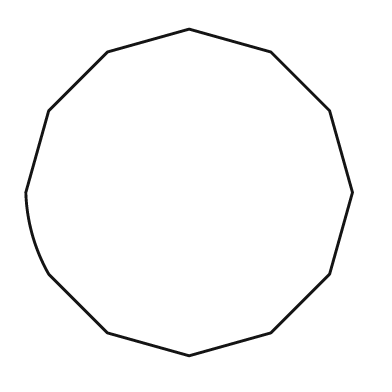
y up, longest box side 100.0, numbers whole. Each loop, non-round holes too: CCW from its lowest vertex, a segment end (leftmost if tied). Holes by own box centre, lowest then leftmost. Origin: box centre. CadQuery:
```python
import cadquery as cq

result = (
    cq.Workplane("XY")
    .moveTo(0.0, -50.0)
    .lineTo(25.0, -43.0)
    .lineTo(43.0, -25.0)
    .lineTo(50.0, 0.0)
    .lineTo(43.0, 25.0)
    .lineTo(25.0, 43.0)
    .lineTo(0.0, 50.0)
    .lineTo(-25.0, 43.0)
    .lineTo(-43.0, 25.0)
    .lineTo(-50.0, 0.0)
    .threePointArc((-48.0, -13.0), (-43.0, -25.0))
    .lineTo(-25.0, -43.0)
    .close()
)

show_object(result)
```